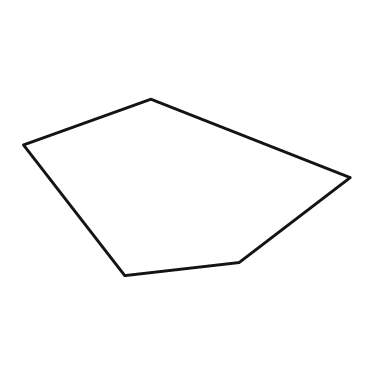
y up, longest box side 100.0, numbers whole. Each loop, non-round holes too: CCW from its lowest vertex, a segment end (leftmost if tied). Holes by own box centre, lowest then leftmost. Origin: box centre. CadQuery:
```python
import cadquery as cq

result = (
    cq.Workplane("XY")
    .moveTo(-19.0, -27.0)
    .lineTo(16.0, -23.0)
    .lineTo(50.0, 3.0)
    .lineTo(-11.0, 27.0)
    .lineTo(-50.0, 13.0)
    .close()
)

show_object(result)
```